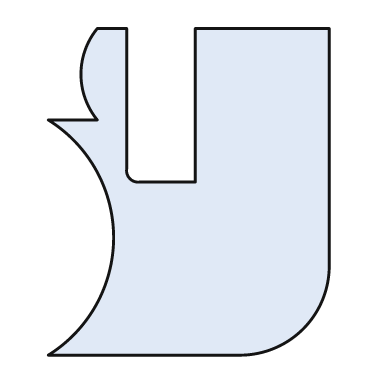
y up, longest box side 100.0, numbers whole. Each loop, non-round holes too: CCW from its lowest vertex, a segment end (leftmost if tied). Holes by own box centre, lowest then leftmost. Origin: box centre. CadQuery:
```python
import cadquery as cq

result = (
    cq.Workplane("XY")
    .moveTo(-43.0, -50.0)
    .lineTo(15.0, -50.0)
    .threePointArc((35.0, -42.0), (43.0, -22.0))
    .lineTo(43.0, 50.0)
    .lineTo(2.0, 50.0)
    .lineTo(2.0, 3.0)
    .lineTo(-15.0, 3.0)
    .threePointArc((-18.0, 4.0), (-19.0, 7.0))
    .lineTo(-19.0, 50.0)
    .lineTo(-28.0, 50.0)
    .threePointArc((-33.0, 36.0), (-28.0, 22.0))
    .lineTo(-43.0, 22.0)
    .threePointArc((-23.0, -14.0), (-43.0, -50.0))
    .close()
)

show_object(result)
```